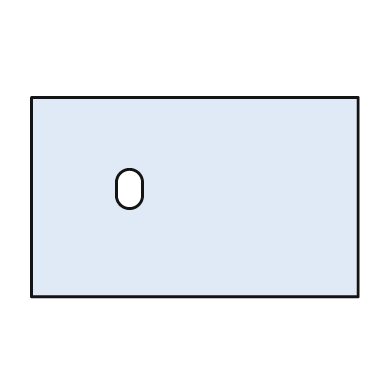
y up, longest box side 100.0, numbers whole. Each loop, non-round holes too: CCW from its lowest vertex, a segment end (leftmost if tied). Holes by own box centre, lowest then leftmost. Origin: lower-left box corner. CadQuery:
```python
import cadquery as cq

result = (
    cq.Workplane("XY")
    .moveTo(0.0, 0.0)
    .lineTo(100.0, 0.0)
    .lineTo(100.0, 61.0)
    .lineTo(0.0, 61.0)
    .close()
    .moveTo(26.0, 31.0)
    .threePointArc((30.0, 27.0), (34.0, 31.0))
    .lineTo(34.0, 35.0)
    .threePointArc((30.0, 39.0), (26.0, 35.0))
    .close()
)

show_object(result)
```